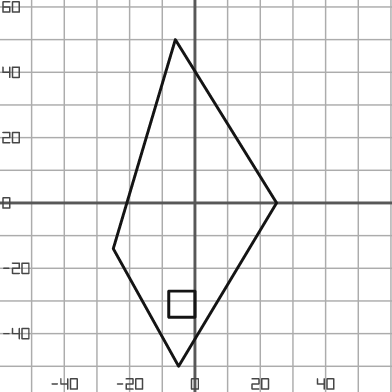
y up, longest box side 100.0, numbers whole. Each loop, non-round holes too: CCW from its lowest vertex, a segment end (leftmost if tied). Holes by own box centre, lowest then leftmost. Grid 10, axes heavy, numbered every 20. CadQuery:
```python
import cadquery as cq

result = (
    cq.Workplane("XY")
    .moveTo(-5.0, -50.0)
    .lineTo(25.0, 0.0)
    .lineTo(-6.0, 50.0)
    .lineTo(-25.0, -14.0)
    .close()
    .moveTo(-8.0, -35.0)
    .lineTo(0.0, -35.0)
    .lineTo(0.0, -27.0)
    .lineTo(-8.0, -27.0)
    .close()
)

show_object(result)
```